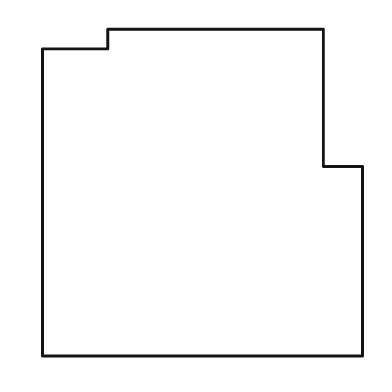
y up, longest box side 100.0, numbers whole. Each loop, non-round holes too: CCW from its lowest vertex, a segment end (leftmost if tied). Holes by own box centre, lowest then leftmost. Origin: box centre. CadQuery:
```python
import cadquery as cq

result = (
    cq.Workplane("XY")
    .moveTo(-49.0, -50.0)
    .lineTo(49.0, -50.0)
    .lineTo(49.0, 8.0)
    .lineTo(37.0, 8.0)
    .lineTo(37.0, 50.0)
    .lineTo(-29.0, 50.0)
    .lineTo(-29.0, 44.0)
    .lineTo(-49.0, 44.0)
    .close()
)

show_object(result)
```